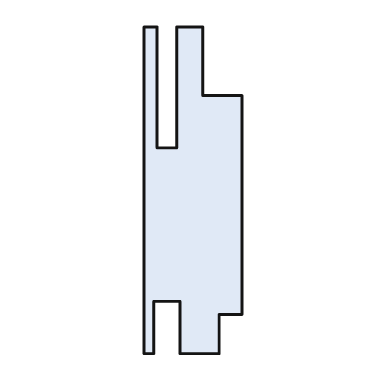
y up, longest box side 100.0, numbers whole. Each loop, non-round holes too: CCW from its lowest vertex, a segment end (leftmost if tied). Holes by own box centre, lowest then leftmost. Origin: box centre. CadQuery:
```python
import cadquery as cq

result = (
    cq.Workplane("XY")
    .moveTo(-15.0, -50.0)
    .lineTo(-12.0, -50.0)
    .lineTo(-12.0, -34.0)
    .lineTo(-4.0, -34.0)
    .lineTo(-4.0, -50.0)
    .lineTo(8.0, -50.0)
    .lineTo(8.0, -38.0)
    .lineTo(15.0, -38.0)
    .lineTo(15.0, 29.0)
    .lineTo(3.0, 29.0)
    .lineTo(3.0, 50.0)
    .lineTo(-5.0, 50.0)
    .lineTo(-5.0, 13.0)
    .lineTo(-11.0, 13.0)
    .lineTo(-11.0, 50.0)
    .lineTo(-15.0, 50.0)
    .close()
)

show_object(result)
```